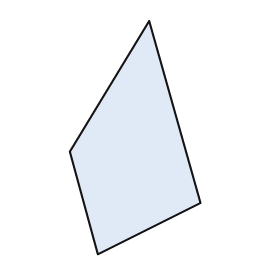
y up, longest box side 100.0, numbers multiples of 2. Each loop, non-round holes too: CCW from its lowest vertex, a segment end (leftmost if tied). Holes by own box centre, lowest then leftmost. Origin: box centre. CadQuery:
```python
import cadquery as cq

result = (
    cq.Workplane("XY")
    .moveTo(-16.0, -50.0)
    .lineTo(28.0, -28.0)
    .lineTo(6.0, 50.0)
    .lineTo(-28.0, -6.0)
    .close()
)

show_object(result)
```